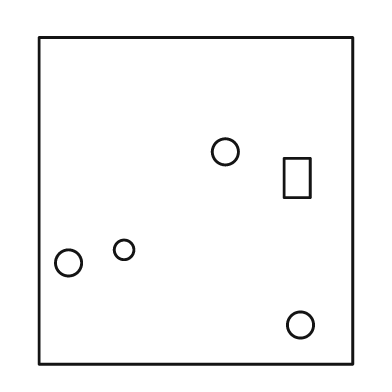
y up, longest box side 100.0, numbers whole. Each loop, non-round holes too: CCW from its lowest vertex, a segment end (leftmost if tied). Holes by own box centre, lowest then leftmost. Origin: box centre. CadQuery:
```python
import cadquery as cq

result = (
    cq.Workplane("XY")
    .moveTo(-48.0, -50.0)
    .lineTo(48.0, -50.0)
    .lineTo(48.0, 50.0)
    .lineTo(-48.0, 50.0)
    .close()
    .moveTo(32.0, -38.0)
    .circle(4.0)
    .moveTo(-39.0, -19.0)
    .circle(4.0)
    .moveTo(-22.0, -15.0)
    .circle(3.0)
    .moveTo(27.0, 1.0)
    .lineTo(35.0, 1.0)
    .lineTo(35.0, 13.0)
    .lineTo(27.0, 13.0)
    .close()
    .moveTo(9.0, 15.0)
    .circle(4.0)
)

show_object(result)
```